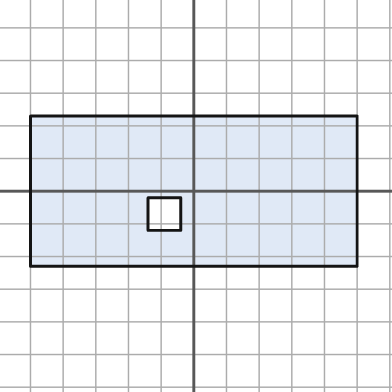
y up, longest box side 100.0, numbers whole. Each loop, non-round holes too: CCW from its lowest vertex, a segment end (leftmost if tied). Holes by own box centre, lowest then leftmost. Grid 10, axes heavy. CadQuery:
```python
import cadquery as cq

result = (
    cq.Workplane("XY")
    .moveTo(-50.0, -23.0)
    .lineTo(50.0, -23.0)
    .lineTo(50.0, 23.0)
    .lineTo(-50.0, 23.0)
    .close()
    .moveTo(-14.0, -12.0)
    .lineTo(-4.0, -12.0)
    .lineTo(-4.0, -2.0)
    .lineTo(-14.0, -2.0)
    .close()
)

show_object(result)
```